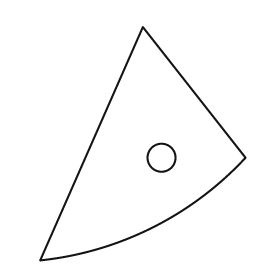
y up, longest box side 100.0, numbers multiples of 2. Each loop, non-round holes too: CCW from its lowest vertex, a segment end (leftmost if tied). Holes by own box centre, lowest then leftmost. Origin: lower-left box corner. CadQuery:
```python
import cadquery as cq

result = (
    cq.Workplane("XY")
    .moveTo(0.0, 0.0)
    .threePointArc((48.0, 14.0), (88.0, 44.0))
    .lineTo(44.0, 100.0)
    .close()
    .moveTo(52.0, 44.0)
    .circle(6.0)
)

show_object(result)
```